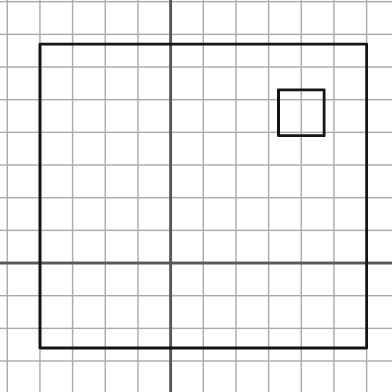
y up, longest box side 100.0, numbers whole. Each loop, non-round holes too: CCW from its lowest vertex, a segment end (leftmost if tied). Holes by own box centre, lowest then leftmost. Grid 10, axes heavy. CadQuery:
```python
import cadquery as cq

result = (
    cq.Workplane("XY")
    .moveTo(-40.0, -26.0)
    .lineTo(60.0, -26.0)
    .lineTo(60.0, 67.0)
    .lineTo(-40.0, 67.0)
    .close()
    .moveTo(33.0, 39.0)
    .lineTo(47.0, 39.0)
    .lineTo(47.0, 53.0)
    .lineTo(33.0, 53.0)
    .close()
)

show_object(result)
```